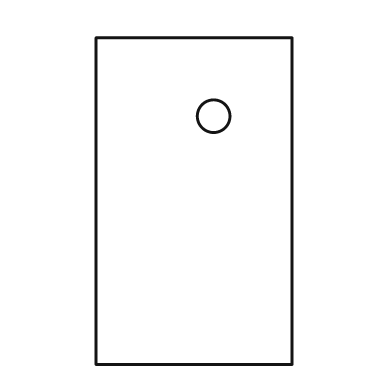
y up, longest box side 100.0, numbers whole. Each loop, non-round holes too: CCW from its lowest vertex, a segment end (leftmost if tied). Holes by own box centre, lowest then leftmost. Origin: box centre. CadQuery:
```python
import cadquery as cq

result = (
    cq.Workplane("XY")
    .moveTo(-30.0, -50.0)
    .lineTo(30.0, -50.0)
    .lineTo(30.0, 50.0)
    .lineTo(-30.0, 50.0)
    .close()
    .moveTo(6.0, 26.0)
    .circle(5.0)
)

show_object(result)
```